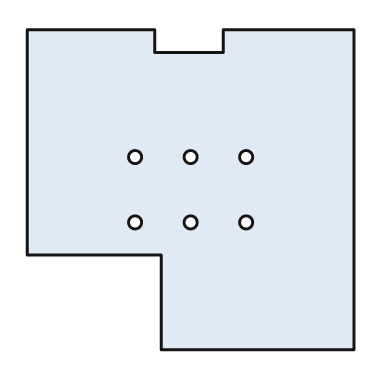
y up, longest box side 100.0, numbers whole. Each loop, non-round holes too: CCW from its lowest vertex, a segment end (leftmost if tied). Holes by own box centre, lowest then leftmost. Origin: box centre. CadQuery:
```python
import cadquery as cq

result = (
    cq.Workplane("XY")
    .moveTo(-9.0, -49.0)
    .lineTo(50.0, -49.0)
    .lineTo(50.0, 49.0)
    .lineTo(10.0, 49.0)
    .lineTo(10.0, 42.0)
    .lineTo(-11.0, 42.0)
    .lineTo(-11.0, 49.0)
    .lineTo(-50.0, 49.0)
    .lineTo(-50.0, -20.0)
    .lineTo(-9.0, -20.0)
    .close()
    .moveTo(-17.0, -10.0)
    .circle(2.0)
    .moveTo(0.0, -10.0)
    .circle(2.0)
    .moveTo(17.0, -10.0)
    .circle(2.0)
    .moveTo(-17.0, 10.0)
    .circle(2.0)
    .moveTo(0.0, 10.0)
    .circle(2.0)
    .moveTo(17.0, 10.0)
    .circle(2.0)
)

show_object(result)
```